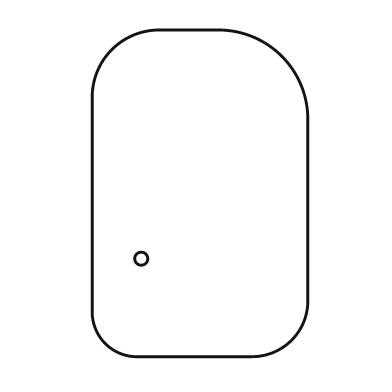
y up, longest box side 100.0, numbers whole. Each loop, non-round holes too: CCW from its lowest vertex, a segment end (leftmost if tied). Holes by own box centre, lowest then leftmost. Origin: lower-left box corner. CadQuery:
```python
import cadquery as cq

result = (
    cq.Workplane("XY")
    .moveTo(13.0, 0.0)
    .lineTo(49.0, 0.0)
    .threePointArc((61.0, 5.0), (66.0, 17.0))
    .lineTo(66.0, 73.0)
    .threePointArc((58.0, 92.0), (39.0, 100.0))
    .lineTo(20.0, 100.0)
    .threePointArc((6.0, 94.0), (0.0, 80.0))
    .lineTo(0.0, 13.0)
    .threePointArc((4.0, 4.0), (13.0, 0.0))
    .close()
    .moveTo(15.0, 30.0)
    .circle(2.0)
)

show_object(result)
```